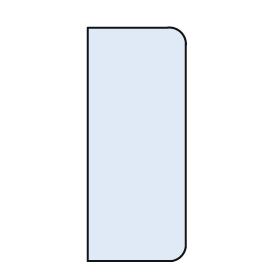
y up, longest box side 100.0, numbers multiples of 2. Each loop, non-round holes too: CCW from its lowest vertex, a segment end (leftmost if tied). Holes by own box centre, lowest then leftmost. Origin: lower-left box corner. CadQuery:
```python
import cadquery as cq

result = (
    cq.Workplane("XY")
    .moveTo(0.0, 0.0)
    .lineTo(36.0, 0.0)
    .threePointArc((40.0, 2.0), (42.0, 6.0))
    .lineTo(42.0, 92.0)
    .threePointArc((40.0, 98.0), (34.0, 100.0))
    .lineTo(0.0, 100.0)
    .close()
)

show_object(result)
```